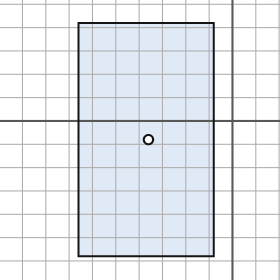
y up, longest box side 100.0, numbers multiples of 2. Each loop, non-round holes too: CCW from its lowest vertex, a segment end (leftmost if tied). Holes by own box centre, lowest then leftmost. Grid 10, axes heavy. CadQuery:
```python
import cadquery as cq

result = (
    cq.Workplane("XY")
    .moveTo(-66.0, -58.0)
    .lineTo(-8.0, -58.0)
    .lineTo(-8.0, 42.0)
    .lineTo(-66.0, 42.0)
    .close()
    .moveTo(-36.0, -8.0)
    .circle(2.0)
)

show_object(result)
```